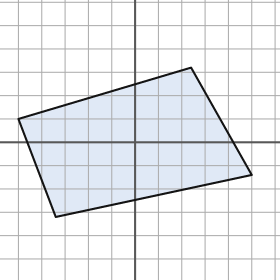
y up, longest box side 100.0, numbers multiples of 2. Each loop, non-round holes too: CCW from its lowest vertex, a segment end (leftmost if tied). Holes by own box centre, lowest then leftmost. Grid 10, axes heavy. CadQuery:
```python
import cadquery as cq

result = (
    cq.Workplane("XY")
    .moveTo(-34.0, -32.0)
    .lineTo(50.0, -14.0)
    .lineTo(24.0, 32.0)
    .lineTo(-50.0, 10.0)
    .close()
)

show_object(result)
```